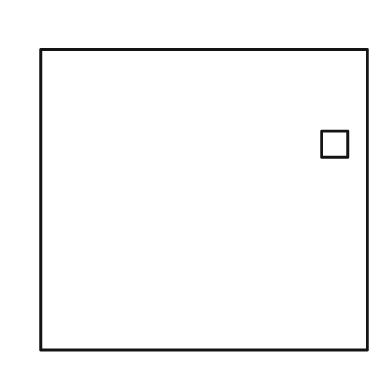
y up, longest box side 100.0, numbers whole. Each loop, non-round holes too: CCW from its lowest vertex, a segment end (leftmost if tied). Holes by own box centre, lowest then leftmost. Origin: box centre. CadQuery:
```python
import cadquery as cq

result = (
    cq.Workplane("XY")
    .moveTo(-50.0, -46.0)
    .lineTo(50.0, -46.0)
    .lineTo(50.0, 46.0)
    .lineTo(-50.0, 46.0)
    .close()
    .moveTo(36.0, 13.0)
    .lineTo(44.0, 13.0)
    .lineTo(44.0, 21.0)
    .lineTo(36.0, 21.0)
    .close()
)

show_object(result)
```